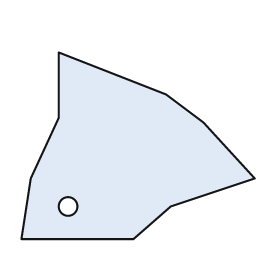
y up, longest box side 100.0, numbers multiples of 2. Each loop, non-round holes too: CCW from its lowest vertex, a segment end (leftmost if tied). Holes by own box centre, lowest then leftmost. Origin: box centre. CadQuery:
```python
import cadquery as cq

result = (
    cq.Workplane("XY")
    .moveTo(-50.0, -40.0)
    .lineTo(-2.0, -40.0)
    .lineTo(14.0, -26.0)
    .lineTo(50.0, -14.0)
    .lineTo(28.0, 10.0)
    .lineTo(12.0, 22.0)
    .lineTo(-34.0, 40.0)
    .lineTo(-34.0, 12.0)
    .lineTo(-46.0, -14.0)
    .close()
    .moveTo(-30.0, -26.0)
    .circle(4.0)
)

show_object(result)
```